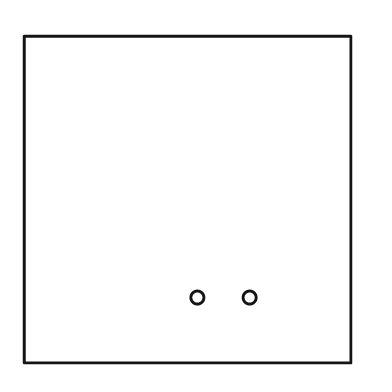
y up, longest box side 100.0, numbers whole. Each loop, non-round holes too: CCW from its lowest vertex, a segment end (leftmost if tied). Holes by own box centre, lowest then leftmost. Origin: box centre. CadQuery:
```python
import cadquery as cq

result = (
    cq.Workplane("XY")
    .moveTo(-50.0, -50.0)
    .lineTo(50.0, -50.0)
    .lineTo(50.0, 50.0)
    .lineTo(-50.0, 50.0)
    .close()
    .moveTo(3.0, -30.0)
    .circle(2.0)
    .moveTo(19.0, -30.0)
    .circle(2.0)
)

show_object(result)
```